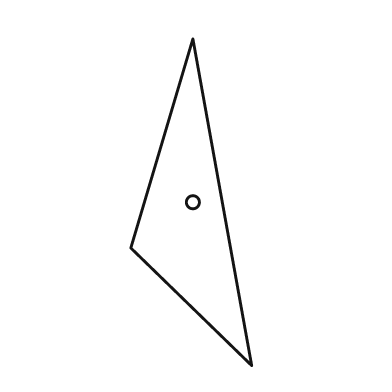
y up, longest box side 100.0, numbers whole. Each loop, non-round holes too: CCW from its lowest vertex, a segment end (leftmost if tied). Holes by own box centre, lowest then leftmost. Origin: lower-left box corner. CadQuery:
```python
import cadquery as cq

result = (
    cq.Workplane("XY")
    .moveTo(37.0, 0.0)
    .lineTo(19.0, 100.0)
    .lineTo(0.0, 36.0)
    .close()
    .moveTo(19.0, 50.0)
    .circle(2.0)
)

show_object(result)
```